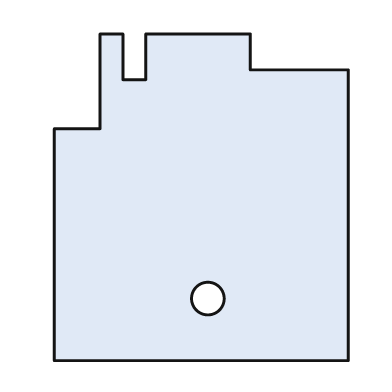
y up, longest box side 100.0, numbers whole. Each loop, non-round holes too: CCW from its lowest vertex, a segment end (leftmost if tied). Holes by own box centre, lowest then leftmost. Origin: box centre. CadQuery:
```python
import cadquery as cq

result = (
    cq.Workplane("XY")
    .moveTo(-45.0, -50.0)
    .lineTo(45.0, -50.0)
    .lineTo(45.0, 39.0)
    .lineTo(15.0, 39.0)
    .lineTo(15.0, 50.0)
    .lineTo(-17.0, 50.0)
    .lineTo(-17.0, 36.0)
    .lineTo(-24.0, 36.0)
    .lineTo(-24.0, 50.0)
    .lineTo(-31.0, 50.0)
    .lineTo(-31.0, 21.0)
    .lineTo(-45.0, 21.0)
    .close()
    .moveTo(2.0, -31.0)
    .circle(5.0)
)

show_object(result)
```